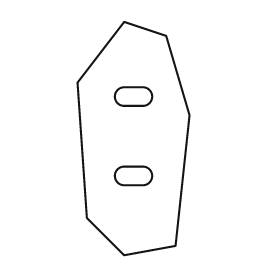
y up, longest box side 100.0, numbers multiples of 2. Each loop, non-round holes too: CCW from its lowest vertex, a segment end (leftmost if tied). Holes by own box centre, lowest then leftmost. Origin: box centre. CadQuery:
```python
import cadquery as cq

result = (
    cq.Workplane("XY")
    .moveTo(-4.0, -50.0)
    .lineTo(18.0, -46.0)
    .lineTo(24.0, 10.0)
    .lineTo(14.0, 44.0)
    .lineTo(-4.0, 50.0)
    .lineTo(-24.0, 24.0)
    .lineTo(-20.0, -34.0)
    .close()
    .moveTo(-4.0, -20.0)
    .lineTo(4.0, -20.0)
    .threePointArc((8.0, -16.0), (4.0, -12.0))
    .lineTo(-4.0, -12.0)
    .threePointArc((-8.0, -16.0), (-4.0, -20.0))
    .close()
    .moveTo(-4.0, 14.0)
    .lineTo(4.0, 14.0)
    .threePointArc((8.0, 18.0), (4.0, 22.0))
    .lineTo(-4.0, 22.0)
    .threePointArc((-8.0, 18.0), (-4.0, 14.0))
    .close()
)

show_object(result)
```